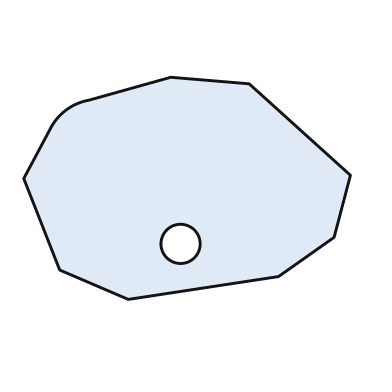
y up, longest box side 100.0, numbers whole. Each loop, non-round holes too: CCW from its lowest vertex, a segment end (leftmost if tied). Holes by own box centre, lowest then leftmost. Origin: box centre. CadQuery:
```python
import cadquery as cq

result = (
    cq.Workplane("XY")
    .moveTo(-18.0, -34.0)
    .lineTo(28.0, -27.0)
    .lineTo(45.0, -15.0)
    .lineTo(50.0, 4.0)
    .lineTo(19.0, 32.0)
    .lineTo(-5.0, 34.0)
    .lineTo(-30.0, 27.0)
    .threePointArc((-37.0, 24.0), (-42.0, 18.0))
    .lineTo(-50.0, 3.0)
    .lineTo(-39.0, -25.0)
    .close()
    .moveTo(-2.0, -17.0)
    .circle(6.0)
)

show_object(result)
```